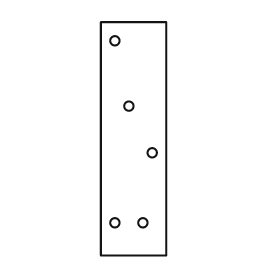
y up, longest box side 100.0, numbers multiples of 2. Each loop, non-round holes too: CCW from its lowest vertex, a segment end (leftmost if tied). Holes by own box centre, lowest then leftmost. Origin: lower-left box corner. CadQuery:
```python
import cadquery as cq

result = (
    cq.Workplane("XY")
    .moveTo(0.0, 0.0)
    .lineTo(28.0, 0.0)
    .lineTo(28.0, 100.0)
    .lineTo(0.0, 100.0)
    .close()
    .moveTo(6.0, 14.0)
    .circle(2.0)
    .moveTo(18.0, 14.0)
    .circle(2.0)
    .moveTo(22.0, 44.0)
    .circle(2.0)
    .moveTo(12.0, 64.0)
    .circle(2.0)
    .moveTo(6.0, 92.0)
    .circle(2.0)
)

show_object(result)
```